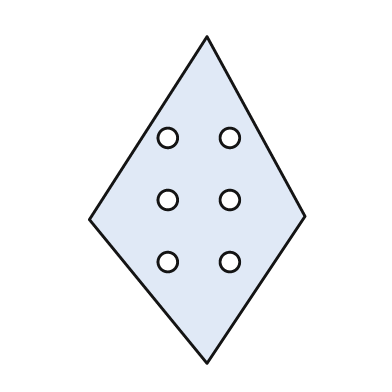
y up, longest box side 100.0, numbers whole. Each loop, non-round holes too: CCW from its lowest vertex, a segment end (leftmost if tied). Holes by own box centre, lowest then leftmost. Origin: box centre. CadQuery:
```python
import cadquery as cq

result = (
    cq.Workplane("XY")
    .moveTo(3.0, -50.0)
    .lineTo(33.0, -5.0)
    .lineTo(3.0, 50.0)
    .lineTo(-33.0, -6.0)
    .close()
    .moveTo(-9.0, -19.0)
    .circle(3.0)
    .moveTo(10.0, -19.0)
    .circle(3.0)
    .moveTo(-9.0, 0.0)
    .circle(3.0)
    .moveTo(10.0, 0.0)
    .circle(3.0)
    .moveTo(-9.0, 19.0)
    .circle(3.0)
    .moveTo(10.0, 19.0)
    .circle(3.0)
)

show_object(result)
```